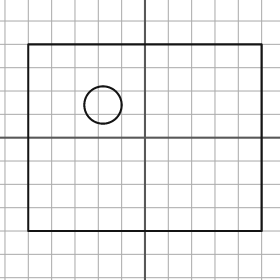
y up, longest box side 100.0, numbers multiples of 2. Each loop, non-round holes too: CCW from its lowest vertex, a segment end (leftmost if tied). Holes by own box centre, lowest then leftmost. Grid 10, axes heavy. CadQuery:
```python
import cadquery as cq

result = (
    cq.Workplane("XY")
    .moveTo(-50.0, -40.0)
    .lineTo(50.0, -40.0)
    .lineTo(50.0, 40.0)
    .lineTo(-50.0, 40.0)
    .close()
    .moveTo(-18.0, 14.0)
    .circle(8.0)
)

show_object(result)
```